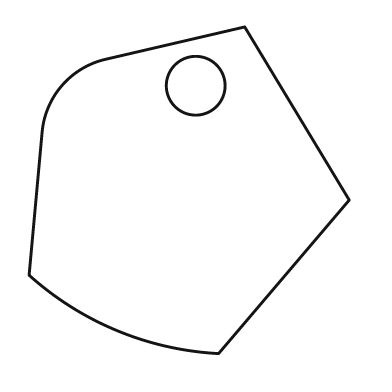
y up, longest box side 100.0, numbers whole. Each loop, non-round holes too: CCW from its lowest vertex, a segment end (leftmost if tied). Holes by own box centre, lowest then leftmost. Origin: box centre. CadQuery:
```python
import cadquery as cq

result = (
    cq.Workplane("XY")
    .moveTo(9.0, -50.0)
    .lineTo(49.0, -3.0)
    .lineTo(17.0, 50.0)
    .lineTo(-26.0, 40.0)
    .threePointArc((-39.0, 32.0), (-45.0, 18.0))
    .lineTo(-49.0, -26.0)
    .threePointArc((-22.0, -43.0), (9.0, -50.0))
    .close()
    .moveTo(2.0, 32.0)
    .circle(9.0)
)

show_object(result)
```